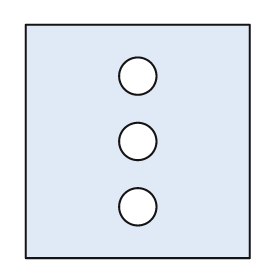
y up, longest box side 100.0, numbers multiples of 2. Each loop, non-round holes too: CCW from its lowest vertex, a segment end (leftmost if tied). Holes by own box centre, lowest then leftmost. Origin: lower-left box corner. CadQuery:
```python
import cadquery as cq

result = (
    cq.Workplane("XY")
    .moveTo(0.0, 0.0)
    .lineTo(96.0, 0.0)
    .lineTo(96.0, 100.0)
    .lineTo(0.0, 100.0)
    .close()
    .moveTo(48.0, 22.0)
    .circle(8.0)
    .moveTo(48.0, 50.0)
    .circle(8.0)
    .moveTo(48.0, 78.0)
    .circle(8.0)
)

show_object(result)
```